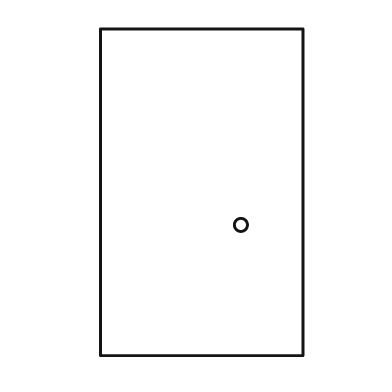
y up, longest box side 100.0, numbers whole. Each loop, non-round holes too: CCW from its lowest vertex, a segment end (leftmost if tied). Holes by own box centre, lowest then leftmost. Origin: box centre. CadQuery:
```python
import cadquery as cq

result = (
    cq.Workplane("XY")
    .moveTo(-31.0, -50.0)
    .lineTo(31.0, -50.0)
    .lineTo(31.0, 50.0)
    .lineTo(-31.0, 50.0)
    .close()
    .moveTo(12.0, -10.0)
    .circle(2.0)
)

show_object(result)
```